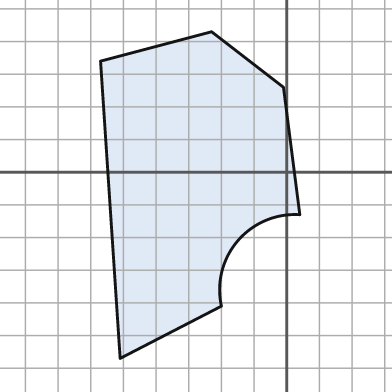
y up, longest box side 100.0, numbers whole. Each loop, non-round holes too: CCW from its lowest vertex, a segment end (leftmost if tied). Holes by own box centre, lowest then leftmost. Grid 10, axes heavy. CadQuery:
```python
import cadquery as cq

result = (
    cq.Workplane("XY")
    .moveTo(-51.0, -57.0)
    .lineTo(-20.0, -41.0)
    .threePointArc((-15.0, -21.0), (4.0, -13.0))
    .lineTo(-1.0, 26.0)
    .lineTo(-23.0, 43.0)
    .lineTo(-57.0, 34.0)
    .close()
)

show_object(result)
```